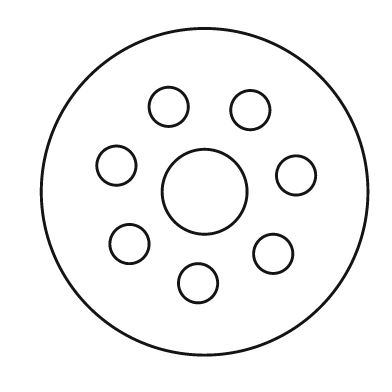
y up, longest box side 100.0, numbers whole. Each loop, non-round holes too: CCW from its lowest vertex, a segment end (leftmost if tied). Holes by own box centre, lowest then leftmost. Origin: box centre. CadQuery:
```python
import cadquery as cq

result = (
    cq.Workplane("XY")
    .moveTo(0.0, 0.0)
    .circle(50.0)
    .moveTo(-2.0, -28.0)
    .circle(6.0)
    .moveTo(21.0, -19.0)
    .circle(6.0)
    .moveTo(-23.0, -16.0)
    .circle(6.0)
    .moveTo(0.0, 0.0)
    .circle(13.0)
    .moveTo(28.0, 5.0)
    .circle(6.0)
    .moveTo(-27.0, 8.0)
    .circle(6.0)
    .moveTo(14.0, 25.0)
    .circle(6.0)
    .moveTo(-11.0, 26.0)
    .circle(6.0)
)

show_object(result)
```